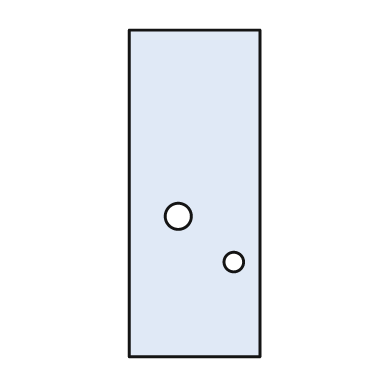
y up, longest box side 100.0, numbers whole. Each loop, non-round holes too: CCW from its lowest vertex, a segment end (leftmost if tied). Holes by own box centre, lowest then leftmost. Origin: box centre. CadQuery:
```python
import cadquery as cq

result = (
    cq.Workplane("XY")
    .moveTo(-20.0, -50.0)
    .lineTo(20.0, -50.0)
    .lineTo(20.0, 50.0)
    .lineTo(-20.0, 50.0)
    .close()
    .moveTo(12.0, -21.0)
    .circle(3.0)
    .moveTo(-5.0, -7.0)
    .circle(4.0)
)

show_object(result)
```